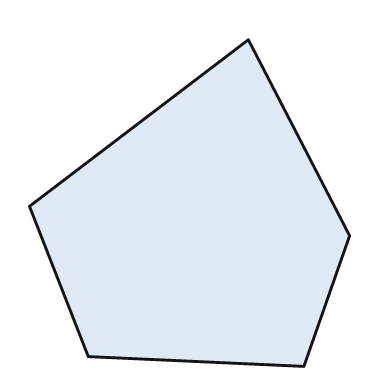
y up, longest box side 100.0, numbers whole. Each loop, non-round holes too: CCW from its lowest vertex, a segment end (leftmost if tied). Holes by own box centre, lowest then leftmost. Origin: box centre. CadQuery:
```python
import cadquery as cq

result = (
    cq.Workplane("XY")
    .moveTo(35.0, -50.0)
    .lineTo(49.0, -10.0)
    .lineTo(18.0, 50.0)
    .lineTo(-49.0, -1.0)
    .lineTo(-31.0, -47.0)
    .close()
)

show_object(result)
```